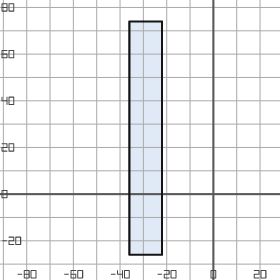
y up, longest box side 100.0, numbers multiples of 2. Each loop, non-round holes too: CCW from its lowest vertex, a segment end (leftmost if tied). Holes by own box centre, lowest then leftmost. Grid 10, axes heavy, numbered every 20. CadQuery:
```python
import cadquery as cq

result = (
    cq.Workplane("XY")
    .moveTo(-36.0, -26.0)
    .lineTo(-22.0, -26.0)
    .lineTo(-22.0, 74.0)
    .lineTo(-36.0, 74.0)
    .close()
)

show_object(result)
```